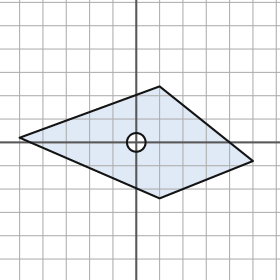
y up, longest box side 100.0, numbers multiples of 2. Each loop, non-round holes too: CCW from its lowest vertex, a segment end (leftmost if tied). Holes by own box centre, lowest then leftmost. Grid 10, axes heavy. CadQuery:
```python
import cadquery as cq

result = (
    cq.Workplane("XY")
    .moveTo(10.0, -24.0)
    .lineTo(50.0, -8.0)
    .lineTo(10.0, 24.0)
    .lineTo(-50.0, 2.0)
    .close()
    .moveTo(0.0, 0.0)
    .circle(4.0)
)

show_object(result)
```